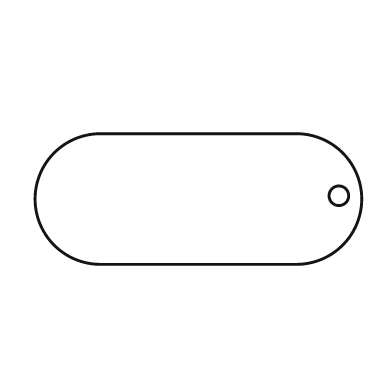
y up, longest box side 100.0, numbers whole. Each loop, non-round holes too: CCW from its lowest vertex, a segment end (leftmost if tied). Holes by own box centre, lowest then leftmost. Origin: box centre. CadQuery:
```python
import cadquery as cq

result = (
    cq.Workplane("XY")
    .moveTo(-30.0, -20.0)
    .lineTo(30.0, -20.0)
    .threePointArc((50.0, 0.0), (30.0, 20.0))
    .lineTo(-30.0, 20.0)
    .threePointArc((-50.0, 0.0), (-30.0, -20.0))
    .close()
    .moveTo(43.0, 1.0)
    .circle(3.0)
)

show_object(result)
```